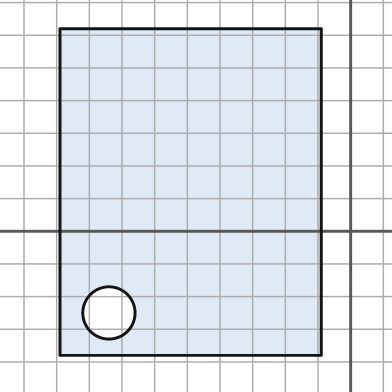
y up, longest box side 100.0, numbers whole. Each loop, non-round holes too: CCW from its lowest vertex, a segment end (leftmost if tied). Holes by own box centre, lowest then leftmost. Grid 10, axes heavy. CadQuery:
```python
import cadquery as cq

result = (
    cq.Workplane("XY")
    .moveTo(-89.0, -38.0)
    .lineTo(-9.0, -38.0)
    .lineTo(-9.0, 62.0)
    .lineTo(-89.0, 62.0)
    .close()
    .moveTo(-74.0, -25.0)
    .circle(8.0)
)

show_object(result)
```